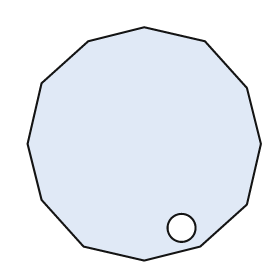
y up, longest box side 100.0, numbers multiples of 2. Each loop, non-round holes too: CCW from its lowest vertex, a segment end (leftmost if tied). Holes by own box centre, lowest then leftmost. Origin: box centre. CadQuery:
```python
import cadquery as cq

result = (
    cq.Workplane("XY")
    .moveTo(0.0, -50.0)
    .lineTo(24.0, -44.0)
    .lineTo(44.0, -26.0)
    .lineTo(50.0, 0.0)
    .lineTo(44.0, 24.0)
    .lineTo(26.0, 44.0)
    .lineTo(0.0, 50.0)
    .lineTo(-24.0, 44.0)
    .lineTo(-44.0, 26.0)
    .lineTo(-50.0, 0.0)
    .lineTo(-44.0, -24.0)
    .lineTo(-26.0, -44.0)
    .close()
    .moveTo(16.0, -36.0)
    .circle(6.0)
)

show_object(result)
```